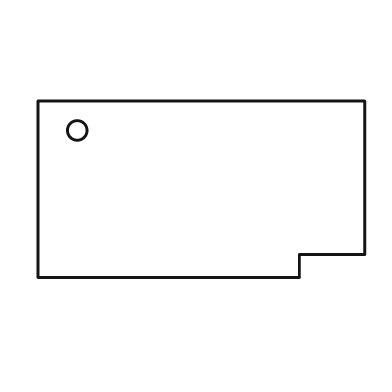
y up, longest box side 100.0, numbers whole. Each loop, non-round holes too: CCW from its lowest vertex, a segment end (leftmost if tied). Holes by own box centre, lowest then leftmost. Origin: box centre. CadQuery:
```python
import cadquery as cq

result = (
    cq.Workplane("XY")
    .moveTo(-50.0, -27.0)
    .lineTo(30.0, -27.0)
    .lineTo(30.0, -20.0)
    .lineTo(50.0, -20.0)
    .lineTo(50.0, 27.0)
    .lineTo(-50.0, 27.0)
    .close()
    .moveTo(-38.0, 18.0)
    .circle(3.0)
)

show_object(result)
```